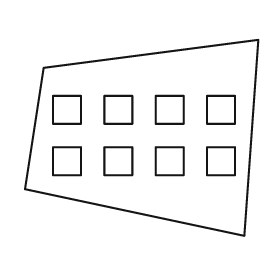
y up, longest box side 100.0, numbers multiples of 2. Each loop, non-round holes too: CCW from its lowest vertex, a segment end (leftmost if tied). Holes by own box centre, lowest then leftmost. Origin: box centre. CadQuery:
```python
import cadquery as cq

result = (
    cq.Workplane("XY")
    .moveTo(44.0, -42.0)
    .lineTo(50.0, 42.0)
    .lineTo(-42.0, 30.0)
    .lineTo(-50.0, -22.0)
    .close()
    .moveTo(-38.0, -16.0)
    .lineTo(-26.0, -16.0)
    .lineTo(-26.0, -4.0)
    .lineTo(-38.0, -4.0)
    .close()
    .moveTo(-16.0, -16.0)
    .lineTo(-4.0, -16.0)
    .lineTo(-4.0, -4.0)
    .lineTo(-16.0, -4.0)
    .close()
    .moveTo(6.0, -16.0)
    .lineTo(18.0, -16.0)
    .lineTo(18.0, -4.0)
    .lineTo(6.0, -4.0)
    .close()
    .moveTo(28.0, -16.0)
    .lineTo(40.0, -16.0)
    .lineTo(40.0, -4.0)
    .lineTo(28.0, -4.0)
    .close()
    .moveTo(-38.0, 6.0)
    .lineTo(-26.0, 6.0)
    .lineTo(-26.0, 18.0)
    .lineTo(-38.0, 18.0)
    .close()
    .moveTo(-16.0, 6.0)
    .lineTo(-4.0, 6.0)
    .lineTo(-4.0, 18.0)
    .lineTo(-16.0, 18.0)
    .close()
    .moveTo(6.0, 6.0)
    .lineTo(18.0, 6.0)
    .lineTo(18.0, 18.0)
    .lineTo(6.0, 18.0)
    .close()
    .moveTo(28.0, 6.0)
    .lineTo(40.0, 6.0)
    .lineTo(40.0, 18.0)
    .lineTo(28.0, 18.0)
    .close()
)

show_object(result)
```